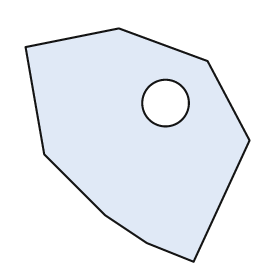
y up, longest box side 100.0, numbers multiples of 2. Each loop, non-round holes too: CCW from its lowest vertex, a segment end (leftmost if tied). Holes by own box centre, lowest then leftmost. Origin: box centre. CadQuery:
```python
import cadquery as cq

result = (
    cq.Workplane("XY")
    .moveTo(24.0, -50.0)
    .lineTo(48.0, 2.0)
    .lineTo(30.0, 36.0)
    .lineTo(-8.0, 50.0)
    .lineTo(-48.0, 42.0)
    .lineTo(-40.0, -4.0)
    .lineTo(-14.0, -30.0)
    .lineTo(4.0, -42.0)
    .close()
    .moveTo(12.0, 18.0)
    .circle(10.0)
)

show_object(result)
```